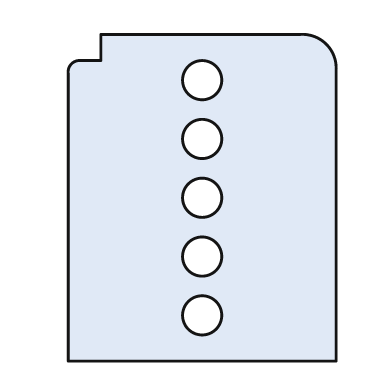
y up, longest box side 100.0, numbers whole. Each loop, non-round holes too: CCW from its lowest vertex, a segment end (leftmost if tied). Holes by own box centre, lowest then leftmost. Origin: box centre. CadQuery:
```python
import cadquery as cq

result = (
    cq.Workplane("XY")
    .moveTo(-41.0, -50.0)
    .lineTo(41.0, -50.0)
    .lineTo(41.0, 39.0)
    .threePointArc((38.0, 47.0), (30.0, 50.0))
    .lineTo(-31.0, 50.0)
    .lineTo(-31.0, 42.0)
    .lineTo(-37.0, 42.0)
    .threePointArc((-40.0, 41.0), (-41.0, 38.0))
    .close()
    .moveTo(0.0, -36.0)
    .circle(6.0)
    .moveTo(0.0, -18.0)
    .circle(6.0)
    .moveTo(0.0, 0.0)
    .circle(6.0)
    .moveTo(0.0, 18.0)
    .circle(6.0)
    .moveTo(0.0, 36.0)
    .circle(6.0)
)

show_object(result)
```